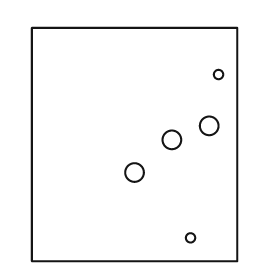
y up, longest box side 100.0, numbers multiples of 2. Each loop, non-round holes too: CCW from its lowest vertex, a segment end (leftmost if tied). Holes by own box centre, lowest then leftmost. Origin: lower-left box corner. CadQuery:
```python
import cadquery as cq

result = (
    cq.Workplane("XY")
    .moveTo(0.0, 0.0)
    .lineTo(88.0, 0.0)
    .lineTo(88.0, 100.0)
    .lineTo(0.0, 100.0)
    .close()
    .moveTo(68.0, 10.0)
    .circle(2.0)
    .moveTo(44.0, 38.0)
    .circle(4.0)
    .moveTo(60.0, 52.0)
    .circle(4.0)
    .moveTo(76.0, 58.0)
    .circle(4.0)
    .moveTo(80.0, 80.0)
    .circle(2.0)
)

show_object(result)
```